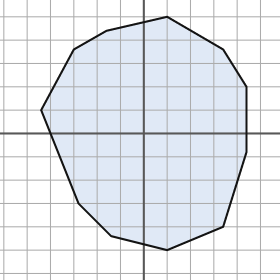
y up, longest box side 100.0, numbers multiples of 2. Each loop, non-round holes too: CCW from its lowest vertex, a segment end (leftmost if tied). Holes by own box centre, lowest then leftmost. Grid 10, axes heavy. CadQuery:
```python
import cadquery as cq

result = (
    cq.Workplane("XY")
    .moveTo(10.0, -50.0)
    .lineTo(34.0, -40.0)
    .lineTo(44.0, -8.0)
    .lineTo(44.0, 20.0)
    .lineTo(34.0, 36.0)
    .lineTo(10.0, 50.0)
    .lineTo(-16.0, 44.0)
    .lineTo(-30.0, 36.0)
    .lineTo(-44.0, 10.0)
    .lineTo(-28.0, -30.0)
    .lineTo(-14.0, -44.0)
    .close()
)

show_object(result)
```